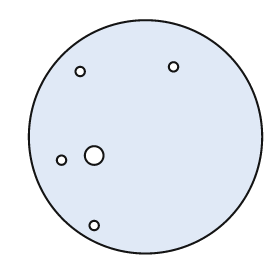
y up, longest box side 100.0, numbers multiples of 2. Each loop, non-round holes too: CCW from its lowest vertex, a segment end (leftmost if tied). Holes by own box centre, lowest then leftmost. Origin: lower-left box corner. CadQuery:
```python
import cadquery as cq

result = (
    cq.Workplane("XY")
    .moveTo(50.0, 50.0)
    .circle(50.0)
    .moveTo(28.0, 12.0)
    .circle(2.0)
    .moveTo(14.0, 40.0)
    .circle(2.0)
    .moveTo(28.0, 42.0)
    .circle(4.0)
    .moveTo(22.0, 78.0)
    .circle(2.0)
    .moveTo(62.0, 80.0)
    .circle(2.0)
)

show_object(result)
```